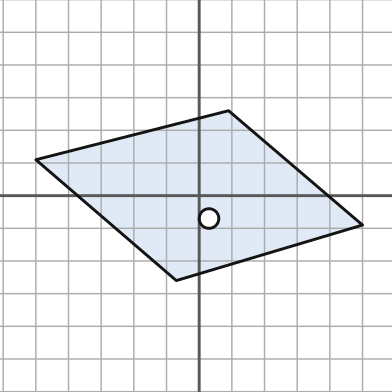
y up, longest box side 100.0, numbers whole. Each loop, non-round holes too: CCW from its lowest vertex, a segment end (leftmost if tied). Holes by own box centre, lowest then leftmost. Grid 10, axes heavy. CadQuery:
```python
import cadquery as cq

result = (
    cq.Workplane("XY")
    .moveTo(-7.0, -26.0)
    .lineTo(50.0, -9.0)
    .lineTo(9.0, 26.0)
    .lineTo(-50.0, 11.0)
    .close()
    .moveTo(3.0, -7.0)
    .circle(3.0)
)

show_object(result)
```